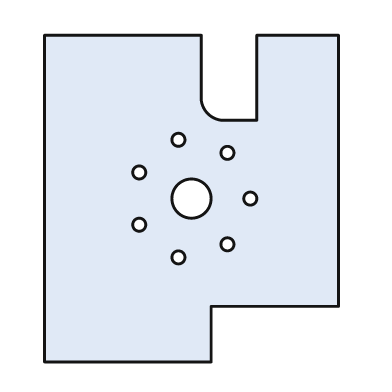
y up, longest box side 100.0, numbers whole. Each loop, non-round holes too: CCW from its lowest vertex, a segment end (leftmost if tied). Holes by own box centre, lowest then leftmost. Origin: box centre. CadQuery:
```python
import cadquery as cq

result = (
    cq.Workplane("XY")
    .moveTo(-45.0, -50.0)
    .lineTo(6.0, -50.0)
    .lineTo(6.0, -33.0)
    .lineTo(45.0, -33.0)
    .lineTo(45.0, 50.0)
    .lineTo(20.0, 50.0)
    .lineTo(20.0, 24.0)
    .lineTo(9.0, 24.0)
    .threePointArc((5.0, 26.0), (3.0, 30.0))
    .lineTo(3.0, 50.0)
    .lineTo(-45.0, 50.0)
    .close()
    .moveTo(-4.0, -18.0)
    .circle(2.0)
    .moveTo(11.0, -14.0)
    .circle(2.0)
    .moveTo(-16.0, -8.0)
    .circle(2.0)
    .moveTo(0.0, 0.0)
    .circle(6.0)
    .moveTo(18.0, 0.0)
    .circle(2.0)
    .moveTo(-16.0, 8.0)
    .circle(2.0)
    .moveTo(11.0, 14.0)
    .circle(2.0)
    .moveTo(-4.0, 18.0)
    .circle(2.0)
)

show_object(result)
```